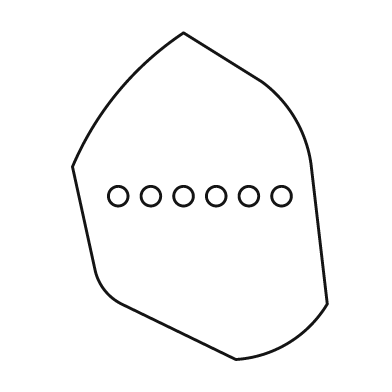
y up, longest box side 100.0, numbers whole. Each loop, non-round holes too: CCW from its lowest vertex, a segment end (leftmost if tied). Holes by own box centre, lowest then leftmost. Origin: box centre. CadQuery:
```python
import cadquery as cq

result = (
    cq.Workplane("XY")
    .moveTo(11.0, -50.0)
    .threePointArc((27.0, -45.0), (39.0, -33.0))
    .lineTo(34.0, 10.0)
    .threePointArc((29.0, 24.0), (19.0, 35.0))
    .lineTo(-5.0, 50.0)
    .threePointArc((-25.0, 32.0), (-39.0, 9.0))
    .lineTo(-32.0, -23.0)
    .threePointArc((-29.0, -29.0), (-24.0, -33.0))
    .close()
    .moveTo(-25.0, 0.0)
    .circle(3.0)
    .moveTo(-15.0, 0.0)
    .circle(3.0)
    .moveTo(-5.0, 0.0)
    .circle(3.0)
    .moveTo(5.0, 0.0)
    .circle(3.0)
    .moveTo(15.0, 0.0)
    .circle(3.0)
    .moveTo(25.0, 0.0)
    .circle(3.0)
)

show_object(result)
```